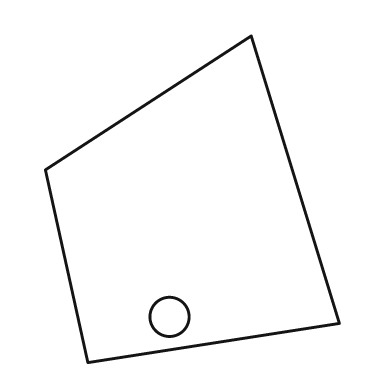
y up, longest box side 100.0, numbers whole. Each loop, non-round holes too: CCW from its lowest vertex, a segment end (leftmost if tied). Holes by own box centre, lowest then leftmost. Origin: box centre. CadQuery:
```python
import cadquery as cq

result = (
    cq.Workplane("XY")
    .moveTo(-32.0, -50.0)
    .lineTo(45.0, -38.0)
    .lineTo(18.0, 50.0)
    .lineTo(-45.0, 9.0)
    .close()
    .moveTo(-7.0, -36.0)
    .circle(6.0)
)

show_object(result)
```